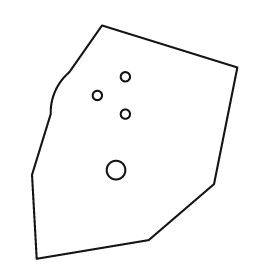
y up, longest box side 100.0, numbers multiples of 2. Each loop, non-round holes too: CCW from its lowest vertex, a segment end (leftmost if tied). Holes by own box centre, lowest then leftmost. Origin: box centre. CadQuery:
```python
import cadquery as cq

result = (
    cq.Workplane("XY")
    .moveTo(-42.0, -50.0)
    .lineTo(6.0, -42.0)
    .lineTo(34.0, -18.0)
    .lineTo(44.0, 32.0)
    .lineTo(-14.0, 50.0)
    .lineTo(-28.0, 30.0)
    .threePointArc((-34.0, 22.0), (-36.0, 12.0))
    .lineTo(-44.0, -14.0)
    .close()
    .moveTo(-8.0, -12.0)
    .circle(4.0)
    .moveTo(-4.0, 12.0)
    .circle(2.0)
    .moveTo(-16.0, 20.0)
    .circle(2.0)
    .moveTo(-4.0, 28.0)
    .circle(2.0)
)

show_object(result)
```